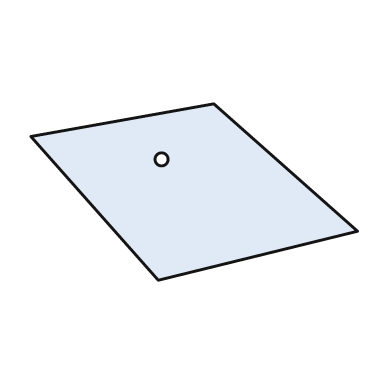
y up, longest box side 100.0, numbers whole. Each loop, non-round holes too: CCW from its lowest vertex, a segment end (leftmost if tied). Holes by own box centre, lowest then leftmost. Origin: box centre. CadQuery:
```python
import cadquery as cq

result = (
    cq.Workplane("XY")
    .moveTo(-11.0, -27.0)
    .lineTo(50.0, -12.0)
    .lineTo(6.0, 27.0)
    .lineTo(-50.0, 17.0)
    .close()
    .moveTo(-10.0, 10.0)
    .circle(2.0)
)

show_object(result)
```